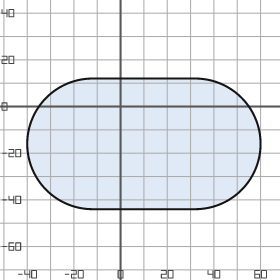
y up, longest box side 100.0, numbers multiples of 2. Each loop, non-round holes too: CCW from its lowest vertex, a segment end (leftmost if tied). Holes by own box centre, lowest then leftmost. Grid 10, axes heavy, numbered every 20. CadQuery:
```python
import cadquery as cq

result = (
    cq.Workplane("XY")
    .moveTo(-12.0, -44.0)
    .lineTo(32.0, -44.0)
    .threePointArc((60.0, -16.0), (32.0, 12.0))
    .lineTo(-12.0, 12.0)
    .threePointArc((-40.0, -16.0), (-12.0, -44.0))
    .close()
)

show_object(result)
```